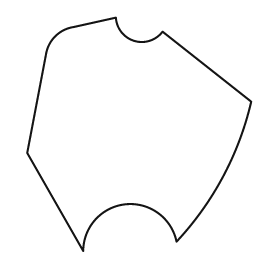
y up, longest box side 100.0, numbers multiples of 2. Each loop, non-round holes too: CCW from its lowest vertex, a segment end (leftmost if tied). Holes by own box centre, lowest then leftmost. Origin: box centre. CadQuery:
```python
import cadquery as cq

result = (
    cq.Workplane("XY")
    .moveTo(-24.0, -50.0)
    .threePointArc((-6.0, -30.0), (16.0, -46.0))
    .threePointArc((36.0, -18.0), (48.0, 14.0))
    .lineTo(10.0, 44.0)
    .threePointArc((-2.0, 40.0), (-10.0, 50.0))
    .lineTo(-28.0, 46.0)
    .threePointArc((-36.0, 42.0), (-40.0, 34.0))
    .lineTo(-48.0, -8.0)
    .close()
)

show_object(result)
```